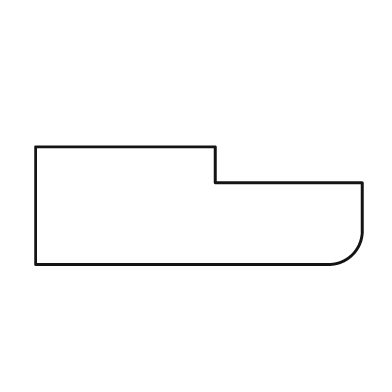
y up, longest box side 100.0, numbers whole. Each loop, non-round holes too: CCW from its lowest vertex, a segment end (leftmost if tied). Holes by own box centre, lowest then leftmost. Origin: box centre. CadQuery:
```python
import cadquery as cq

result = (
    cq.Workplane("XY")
    .moveTo(-50.0, -18.0)
    .lineTo(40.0, -18.0)
    .threePointArc((47.0, -15.0), (50.0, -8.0))
    .lineTo(50.0, 7.0)
    .lineTo(5.0, 7.0)
    .lineTo(5.0, 18.0)
    .lineTo(-50.0, 18.0)
    .close()
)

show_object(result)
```